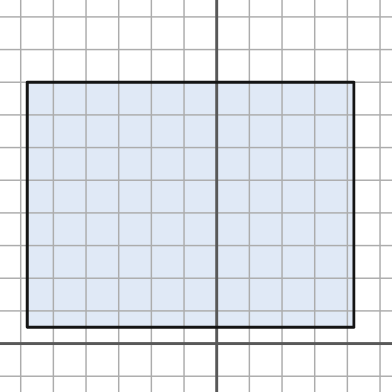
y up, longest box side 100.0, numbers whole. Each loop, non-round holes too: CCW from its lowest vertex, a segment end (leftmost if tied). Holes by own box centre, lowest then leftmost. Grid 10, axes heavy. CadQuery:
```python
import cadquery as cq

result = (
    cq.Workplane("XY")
    .moveTo(-58.0, 5.0)
    .lineTo(42.0, 5.0)
    .lineTo(42.0, 80.0)
    .lineTo(-58.0, 80.0)
    .close()
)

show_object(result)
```